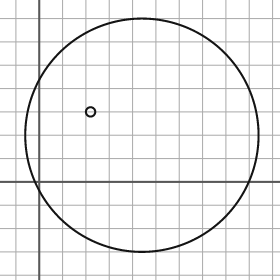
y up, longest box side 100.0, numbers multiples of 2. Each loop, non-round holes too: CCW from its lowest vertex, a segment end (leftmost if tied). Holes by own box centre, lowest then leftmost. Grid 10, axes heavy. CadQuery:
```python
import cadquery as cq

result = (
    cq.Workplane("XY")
    .moveTo(44.0, 20.0)
    .circle(50.0)
    .moveTo(22.0, 30.0)
    .circle(2.0)
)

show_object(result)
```